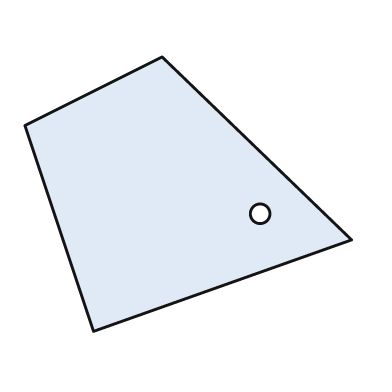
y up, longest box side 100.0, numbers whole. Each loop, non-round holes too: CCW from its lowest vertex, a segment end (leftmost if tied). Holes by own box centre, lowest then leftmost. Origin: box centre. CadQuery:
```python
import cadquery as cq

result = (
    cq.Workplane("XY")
    .moveTo(-29.0, -42.0)
    .lineTo(50.0, -14.0)
    .lineTo(-8.0, 42.0)
    .lineTo(-50.0, 21.0)
    .close()
    .moveTo(22.0, -6.0)
    .circle(3.0)
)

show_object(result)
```